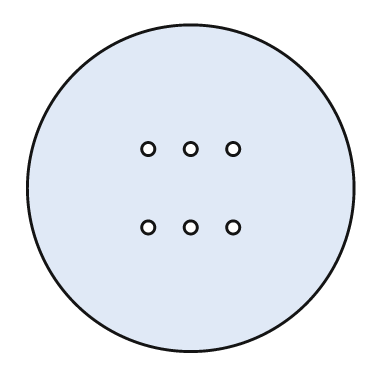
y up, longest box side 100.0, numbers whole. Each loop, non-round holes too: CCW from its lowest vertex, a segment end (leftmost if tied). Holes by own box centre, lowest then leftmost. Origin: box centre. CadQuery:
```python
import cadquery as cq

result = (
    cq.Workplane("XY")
    .moveTo(0.0, 0.0)
    .circle(50.0)
    .moveTo(-13.0, -12.0)
    .circle(2.0)
    .moveTo(0.0, -12.0)
    .circle(2.0)
    .moveTo(13.0, -12.0)
    .circle(2.0)
    .moveTo(-13.0, 12.0)
    .circle(2.0)
    .moveTo(0.0, 12.0)
    .circle(2.0)
    .moveTo(13.0, 12.0)
    .circle(2.0)
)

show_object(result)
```